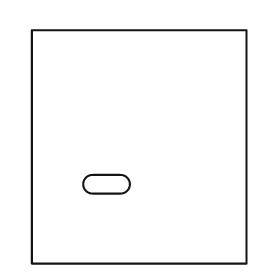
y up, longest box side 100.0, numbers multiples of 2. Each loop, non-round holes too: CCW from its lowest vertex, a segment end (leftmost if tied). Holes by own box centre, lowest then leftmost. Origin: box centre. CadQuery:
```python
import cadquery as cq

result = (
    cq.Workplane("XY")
    .moveTo(-46.0, -50.0)
    .lineTo(46.0, -50.0)
    .lineTo(46.0, 50.0)
    .lineTo(-46.0, 50.0)
    .close()
    .moveTo(-20.0, -20.0)
    .lineTo(-8.0, -20.0)
    .threePointArc((-4.0, -16.0), (-8.0, -12.0))
    .lineTo(-20.0, -12.0)
    .threePointArc((-24.0, -16.0), (-20.0, -20.0))
    .close()
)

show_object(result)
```